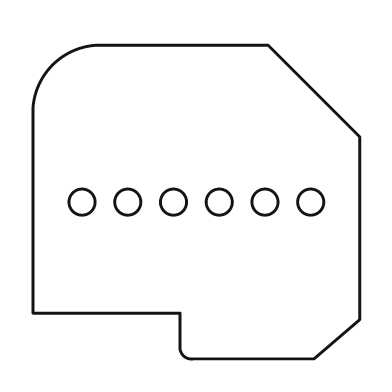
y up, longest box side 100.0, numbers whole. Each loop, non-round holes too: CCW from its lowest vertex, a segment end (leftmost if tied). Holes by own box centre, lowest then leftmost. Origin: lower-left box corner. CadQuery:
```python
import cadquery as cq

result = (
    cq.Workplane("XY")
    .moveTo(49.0, 0.0)
    .lineTo(86.0, 0.0)
    .lineTo(100.0, 12.0)
    .lineTo(100.0, 68.0)
    .lineTo(72.0, 96.0)
    .lineTo(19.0, 96.0)
    .threePointArc((6.0, 90.0), (0.0, 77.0))
    .lineTo(0.0, 14.0)
    .lineTo(45.0, 14.0)
    .lineTo(45.0, 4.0)
    .threePointArc((46.0, 1.0), (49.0, 0.0))
    .close()
    .moveTo(15.0, 48.0)
    .circle(4.0)
    .moveTo(29.0, 48.0)
    .circle(4.0)
    .moveTo(43.0, 48.0)
    .circle(4.0)
    .moveTo(57.0, 48.0)
    .circle(4.0)
    .moveTo(71.0, 48.0)
    .circle(4.0)
    .moveTo(85.0, 48.0)
    .circle(4.0)
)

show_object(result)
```